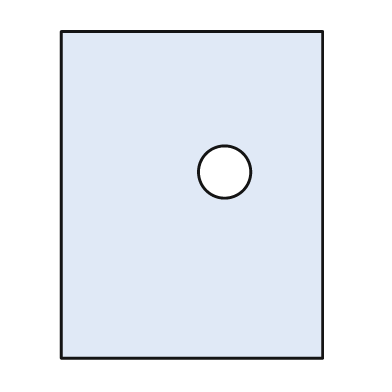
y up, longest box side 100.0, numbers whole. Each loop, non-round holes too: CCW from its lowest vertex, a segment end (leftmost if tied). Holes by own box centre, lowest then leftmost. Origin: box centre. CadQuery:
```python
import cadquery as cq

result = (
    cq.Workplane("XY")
    .moveTo(-40.0, -50.0)
    .lineTo(40.0, -50.0)
    .lineTo(40.0, 50.0)
    .lineTo(-40.0, 50.0)
    .close()
    .moveTo(10.0, 7.0)
    .circle(8.0)
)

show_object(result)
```